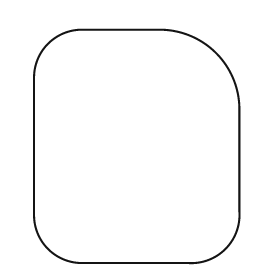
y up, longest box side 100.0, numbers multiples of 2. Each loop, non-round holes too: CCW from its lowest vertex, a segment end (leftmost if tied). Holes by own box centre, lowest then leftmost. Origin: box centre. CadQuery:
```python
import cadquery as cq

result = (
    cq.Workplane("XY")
    .moveTo(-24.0, -50.0)
    .lineTo(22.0, -50.0)
    .threePointArc((38.0, -44.0), (44.0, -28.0))
    .lineTo(44.0, 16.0)
    .threePointArc((34.0, 40.0), (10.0, 50.0))
    .lineTo(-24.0, 50.0)
    .threePointArc((-38.0, 44.0), (-44.0, 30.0))
    .lineTo(-44.0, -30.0)
    .threePointArc((-38.0, -44.0), (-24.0, -50.0))
    .close()
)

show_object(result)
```